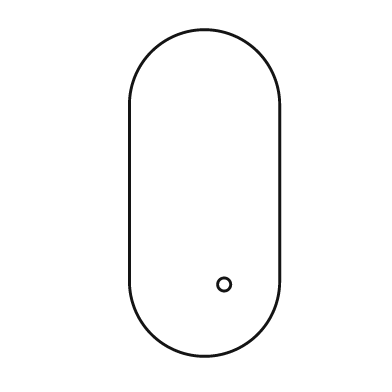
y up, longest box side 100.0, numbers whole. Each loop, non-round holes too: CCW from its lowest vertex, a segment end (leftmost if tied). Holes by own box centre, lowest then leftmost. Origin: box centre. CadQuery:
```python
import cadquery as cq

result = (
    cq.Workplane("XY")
    .moveTo(-23.0, -27.0)
    .threePointArc((0.0, -50.0), (23.0, -27.0))
    .lineTo(23.0, 27.0)
    .threePointArc((0.0, 50.0), (-23.0, 27.0))
    .close()
    .moveTo(6.0, -28.0)
    .circle(2.0)
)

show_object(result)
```